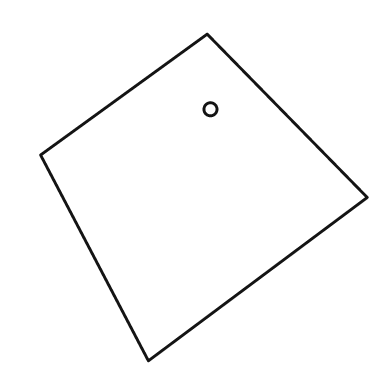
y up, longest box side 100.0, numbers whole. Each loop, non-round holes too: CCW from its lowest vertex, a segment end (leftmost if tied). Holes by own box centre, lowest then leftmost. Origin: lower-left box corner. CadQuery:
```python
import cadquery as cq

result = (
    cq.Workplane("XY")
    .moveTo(33.0, 0.0)
    .lineTo(100.0, 50.0)
    .lineTo(51.0, 100.0)
    .lineTo(0.0, 63.0)
    .close()
    .moveTo(52.0, 77.0)
    .circle(2.0)
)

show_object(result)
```